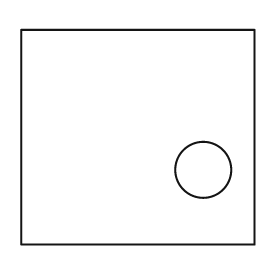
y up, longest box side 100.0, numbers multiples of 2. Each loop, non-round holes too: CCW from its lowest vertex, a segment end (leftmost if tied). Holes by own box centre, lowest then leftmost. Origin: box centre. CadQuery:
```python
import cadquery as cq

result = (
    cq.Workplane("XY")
    .moveTo(-50.0, -46.0)
    .lineTo(50.0, -46.0)
    .lineTo(50.0, 46.0)
    .lineTo(-50.0, 46.0)
    .close()
    .moveTo(28.0, -14.0)
    .circle(12.0)
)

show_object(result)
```